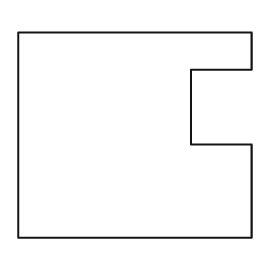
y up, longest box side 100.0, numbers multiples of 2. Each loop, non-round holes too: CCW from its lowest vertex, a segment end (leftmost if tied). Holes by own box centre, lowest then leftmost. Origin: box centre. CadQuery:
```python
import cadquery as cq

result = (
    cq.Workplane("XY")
    .moveTo(-50.0, -44.0)
    .lineTo(50.0, -44.0)
    .lineTo(50.0, -4.0)
    .lineTo(24.0, -4.0)
    .lineTo(24.0, 28.0)
    .lineTo(50.0, 28.0)
    .lineTo(50.0, 44.0)
    .lineTo(-50.0, 44.0)
    .close()
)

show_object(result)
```